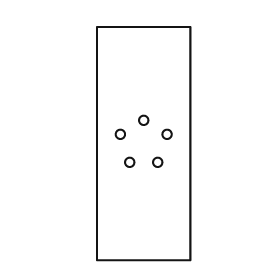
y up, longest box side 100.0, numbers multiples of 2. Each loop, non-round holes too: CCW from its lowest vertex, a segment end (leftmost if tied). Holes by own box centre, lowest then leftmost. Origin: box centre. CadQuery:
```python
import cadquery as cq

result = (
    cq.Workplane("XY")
    .moveTo(-20.0, -50.0)
    .lineTo(20.0, -50.0)
    .lineTo(20.0, 50.0)
    .lineTo(-20.0, 50.0)
    .close()
    .moveTo(-6.0, -8.0)
    .circle(2.0)
    .moveTo(6.0, -8.0)
    .circle(2.0)
    .moveTo(-10.0, 4.0)
    .circle(2.0)
    .moveTo(10.0, 4.0)
    .circle(2.0)
    .moveTo(0.0, 10.0)
    .circle(2.0)
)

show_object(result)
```